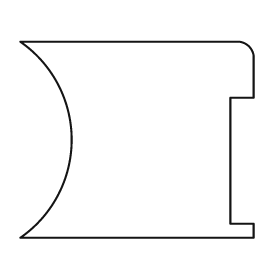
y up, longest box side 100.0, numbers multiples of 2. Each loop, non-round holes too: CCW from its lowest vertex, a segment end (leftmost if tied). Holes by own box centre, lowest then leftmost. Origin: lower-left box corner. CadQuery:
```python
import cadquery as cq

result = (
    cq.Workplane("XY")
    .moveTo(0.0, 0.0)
    .lineTo(100.0, 0.0)
    .lineTo(100.0, 6.0)
    .lineTo(90.0, 6.0)
    .lineTo(90.0, 60.0)
    .lineTo(100.0, 60.0)
    .lineTo(100.0, 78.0)
    .threePointArc((98.0, 82.0), (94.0, 84.0))
    .lineTo(0.0, 84.0)
    .threePointArc((22.0, 42.0), (0.0, 0.0))
    .close()
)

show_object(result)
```